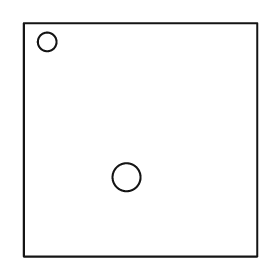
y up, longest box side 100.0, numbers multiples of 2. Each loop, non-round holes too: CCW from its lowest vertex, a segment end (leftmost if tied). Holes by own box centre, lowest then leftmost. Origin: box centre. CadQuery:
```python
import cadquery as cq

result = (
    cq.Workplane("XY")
    .moveTo(-50.0, -50.0)
    .lineTo(50.0, -50.0)
    .lineTo(50.0, 50.0)
    .lineTo(-50.0, 50.0)
    .close()
    .moveTo(-6.0, -16.0)
    .circle(6.0)
    .moveTo(-40.0, 42.0)
    .circle(4.0)
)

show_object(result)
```